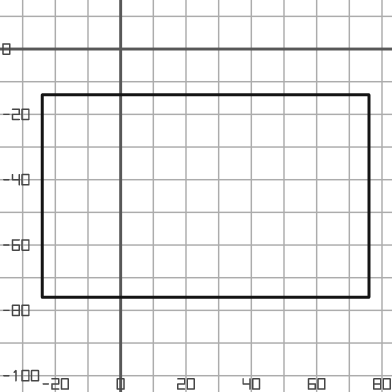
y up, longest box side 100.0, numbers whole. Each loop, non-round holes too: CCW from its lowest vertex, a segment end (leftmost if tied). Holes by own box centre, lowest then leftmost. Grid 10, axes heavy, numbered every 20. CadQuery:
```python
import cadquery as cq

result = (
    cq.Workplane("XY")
    .moveTo(-24.0, -76.0)
    .lineTo(76.0, -76.0)
    .lineTo(76.0, -14.0)
    .lineTo(-24.0, -14.0)
    .close()
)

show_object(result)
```